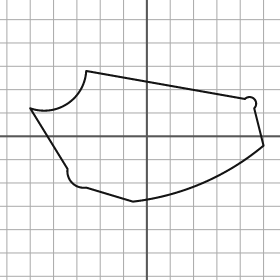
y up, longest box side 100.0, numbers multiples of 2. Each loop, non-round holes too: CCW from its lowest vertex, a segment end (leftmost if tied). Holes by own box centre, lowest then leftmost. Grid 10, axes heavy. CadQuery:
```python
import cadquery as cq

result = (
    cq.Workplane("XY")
    .moveTo(-6.0, -28.0)
    .threePointArc((24.0, -20.0), (50.0, -4.0))
    .lineTo(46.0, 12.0)
    .threePointArc((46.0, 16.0), (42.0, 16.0))
    .lineTo(-26.0, 28.0)
    .threePointArc((-34.0, 14.0), (-50.0, 12.0))
    .lineTo(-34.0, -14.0)
    .threePointArc((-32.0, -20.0), (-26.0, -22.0))
    .close()
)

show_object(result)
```